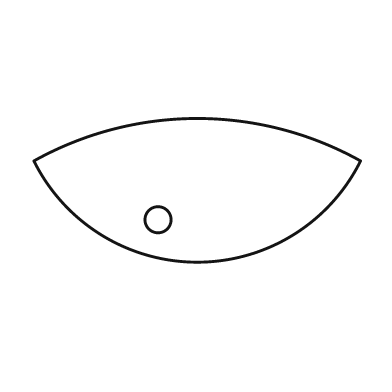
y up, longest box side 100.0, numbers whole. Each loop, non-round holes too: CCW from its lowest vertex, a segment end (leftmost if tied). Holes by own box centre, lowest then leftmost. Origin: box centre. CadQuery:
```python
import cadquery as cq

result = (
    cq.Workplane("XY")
    .moveTo(-50.0, 9.0)
    .threePointArc((0.0, -22.0), (50.0, 9.0))
    .threePointArc((0.0, 22.0), (-50.0, 9.0))
    .close()
    .moveTo(-12.0, -9.0)
    .circle(4.0)
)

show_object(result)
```